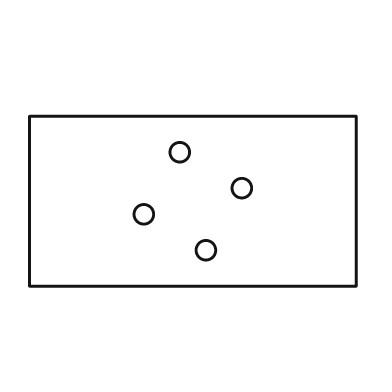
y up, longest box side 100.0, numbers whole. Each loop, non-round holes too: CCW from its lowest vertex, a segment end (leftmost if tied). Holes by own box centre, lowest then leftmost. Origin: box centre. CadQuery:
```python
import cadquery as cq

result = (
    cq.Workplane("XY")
    .moveTo(-50.0, -26.0)
    .lineTo(50.0, -26.0)
    .lineTo(50.0, 26.0)
    .lineTo(-50.0, 26.0)
    .close()
    .moveTo(4.0, -15.0)
    .circle(3.0)
    .moveTo(-15.0, -4.0)
    .circle(3.0)
    .moveTo(15.0, 4.0)
    .circle(3.0)
    .moveTo(-4.0, 15.0)
    .circle(3.0)
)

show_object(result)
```